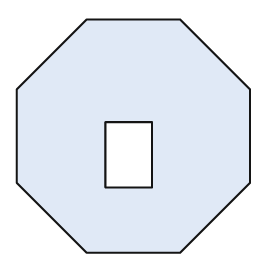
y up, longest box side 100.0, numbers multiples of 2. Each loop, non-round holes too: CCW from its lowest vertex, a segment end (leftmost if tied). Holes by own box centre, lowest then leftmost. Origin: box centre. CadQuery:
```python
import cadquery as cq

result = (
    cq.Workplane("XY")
    .moveTo(-20.0, -50.0)
    .lineTo(20.0, -50.0)
    .lineTo(50.0, -20.0)
    .lineTo(50.0, 20.0)
    .lineTo(20.0, 50.0)
    .lineTo(-20.0, 50.0)
    .lineTo(-50.0, 20.0)
    .lineTo(-50.0, -20.0)
    .close()
    .moveTo(-12.0, -22.0)
    .lineTo(8.0, -22.0)
    .lineTo(8.0, 6.0)
    .lineTo(-12.0, 6.0)
    .close()
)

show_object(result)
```